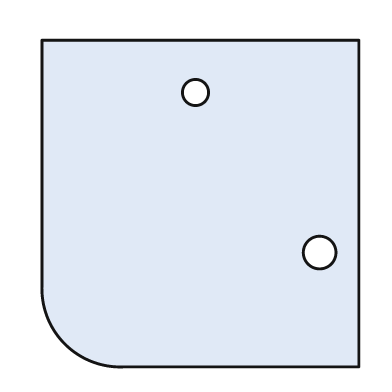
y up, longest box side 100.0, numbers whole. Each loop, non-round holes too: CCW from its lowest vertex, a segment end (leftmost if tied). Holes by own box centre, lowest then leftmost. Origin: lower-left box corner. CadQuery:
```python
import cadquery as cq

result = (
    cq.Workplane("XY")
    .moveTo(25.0, 0.0)
    .lineTo(97.0, 0.0)
    .lineTo(97.0, 100.0)
    .lineTo(0.0, 100.0)
    .lineTo(0.0, 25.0)
    .threePointArc((7.0, 7.0), (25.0, 0.0))
    .close()
    .moveTo(85.0, 35.0)
    .circle(5.0)
    .moveTo(47.0, 84.0)
    .circle(4.0)
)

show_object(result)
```